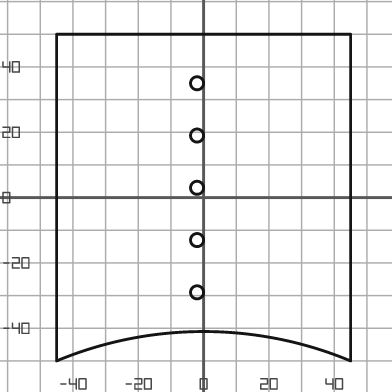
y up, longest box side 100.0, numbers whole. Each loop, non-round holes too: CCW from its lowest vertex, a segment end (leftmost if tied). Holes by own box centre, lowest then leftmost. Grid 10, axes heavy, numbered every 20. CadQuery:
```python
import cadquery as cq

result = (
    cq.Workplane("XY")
    .moveTo(-45.0, -50.0)
    .threePointArc((0.0, -41.0), (45.0, -50.0))
    .lineTo(45.0, 50.0)
    .lineTo(-45.0, 50.0)
    .close()
    .moveTo(-2.0, -29.0)
    .circle(2.0)
    .moveTo(-2.0, -13.0)
    .circle(2.0)
    .moveTo(-2.0, 3.0)
    .circle(2.0)
    .moveTo(-2.0, 19.0)
    .circle(2.0)
    .moveTo(-2.0, 35.0)
    .circle(2.0)
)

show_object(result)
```